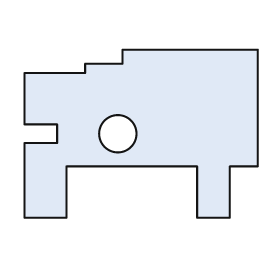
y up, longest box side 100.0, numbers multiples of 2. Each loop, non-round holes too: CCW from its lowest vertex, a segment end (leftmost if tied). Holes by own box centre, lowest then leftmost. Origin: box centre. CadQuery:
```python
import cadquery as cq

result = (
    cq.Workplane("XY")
    .moveTo(-50.0, -36.0)
    .lineTo(-32.0, -36.0)
    .lineTo(-32.0, -14.0)
    .lineTo(24.0, -14.0)
    .lineTo(24.0, -36.0)
    .lineTo(38.0, -36.0)
    .lineTo(38.0, -14.0)
    .lineTo(50.0, -14.0)
    .lineTo(50.0, 36.0)
    .lineTo(-8.0, 36.0)
    .lineTo(-8.0, 30.0)
    .lineTo(-24.0, 30.0)
    .lineTo(-24.0, 26.0)
    .lineTo(-50.0, 26.0)
    .lineTo(-50.0, 4.0)
    .lineTo(-36.0, 4.0)
    .lineTo(-36.0, -4.0)
    .lineTo(-50.0, -4.0)
    .close()
    .moveTo(-10.0, 0.0)
    .circle(8.0)
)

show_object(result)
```